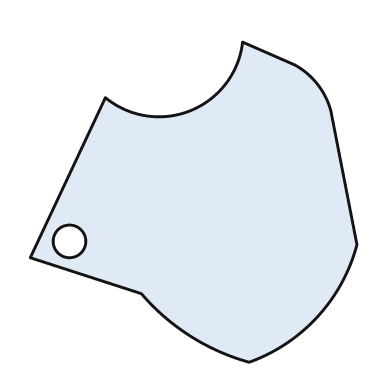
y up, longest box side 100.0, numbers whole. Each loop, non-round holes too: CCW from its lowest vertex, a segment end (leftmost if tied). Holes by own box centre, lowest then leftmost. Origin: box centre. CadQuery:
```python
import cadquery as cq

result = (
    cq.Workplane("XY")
    .moveTo(17.0, -49.0)
    .threePointArc((38.0, -35.0), (50.0, -13.0))
    .lineTo(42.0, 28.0)
    .threePointArc((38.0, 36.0), (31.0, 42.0))
    .lineTo(15.0, 49.0)
    .threePointArc((-1.0, 28.0), (-27.0, 32.0))
    .lineTo(-50.0, -17.0)
    .lineTo(-16.0, -28.0)
    .threePointArc((-1.0, -41.0), (17.0, -49.0))
    .close()
    .moveTo(-38.0, -12.0)
    .circle(5.0)
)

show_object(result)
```